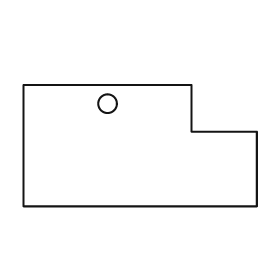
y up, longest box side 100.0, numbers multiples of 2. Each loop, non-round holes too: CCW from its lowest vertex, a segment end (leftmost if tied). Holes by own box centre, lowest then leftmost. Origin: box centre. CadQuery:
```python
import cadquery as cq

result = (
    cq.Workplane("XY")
    .moveTo(-50.0, -26.0)
    .lineTo(50.0, -26.0)
    .lineTo(50.0, 6.0)
    .lineTo(22.0, 6.0)
    .lineTo(22.0, 26.0)
    .lineTo(-50.0, 26.0)
    .close()
    .moveTo(-14.0, 18.0)
    .circle(4.0)
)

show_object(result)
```